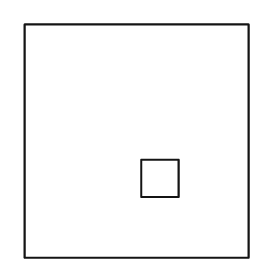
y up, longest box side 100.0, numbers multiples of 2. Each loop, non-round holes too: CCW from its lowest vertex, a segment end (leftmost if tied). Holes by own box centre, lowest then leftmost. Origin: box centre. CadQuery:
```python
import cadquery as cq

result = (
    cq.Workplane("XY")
    .moveTo(-48.0, -50.0)
    .lineTo(48.0, -50.0)
    .lineTo(48.0, 50.0)
    .lineTo(-48.0, 50.0)
    .close()
    .moveTo(2.0, -24.0)
    .lineTo(18.0, -24.0)
    .lineTo(18.0, -8.0)
    .lineTo(2.0, -8.0)
    .close()
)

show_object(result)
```